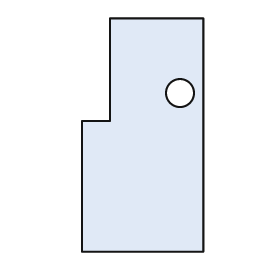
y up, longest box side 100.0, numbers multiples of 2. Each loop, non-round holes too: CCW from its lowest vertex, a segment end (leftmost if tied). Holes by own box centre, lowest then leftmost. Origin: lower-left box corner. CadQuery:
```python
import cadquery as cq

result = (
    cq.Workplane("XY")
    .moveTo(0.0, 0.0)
    .lineTo(52.0, 0.0)
    .lineTo(52.0, 100.0)
    .lineTo(12.0, 100.0)
    .lineTo(12.0, 56.0)
    .lineTo(0.0, 56.0)
    .close()
    .moveTo(42.0, 68.0)
    .circle(6.0)
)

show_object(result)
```